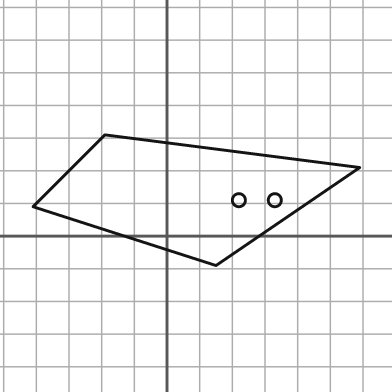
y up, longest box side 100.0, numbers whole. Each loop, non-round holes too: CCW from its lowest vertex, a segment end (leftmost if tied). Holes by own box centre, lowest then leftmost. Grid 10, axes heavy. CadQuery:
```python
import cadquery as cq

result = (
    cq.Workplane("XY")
    .moveTo(15.0, -9.0)
    .lineTo(59.0, 21.0)
    .lineTo(-19.0, 31.0)
    .lineTo(-41.0, 9.0)
    .close()
    .moveTo(22.0, 11.0)
    .circle(2.0)
    .moveTo(33.0, 11.0)
    .circle(2.0)
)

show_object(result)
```